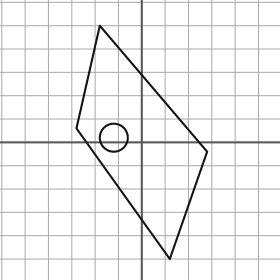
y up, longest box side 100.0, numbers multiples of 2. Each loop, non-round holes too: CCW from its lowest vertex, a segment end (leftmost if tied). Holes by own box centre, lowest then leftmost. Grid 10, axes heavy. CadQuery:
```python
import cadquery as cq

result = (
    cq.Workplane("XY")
    .moveTo(12.0, -50.0)
    .lineTo(28.0, -4.0)
    .lineTo(-18.0, 50.0)
    .lineTo(-28.0, 6.0)
    .close()
    .moveTo(-12.0, 2.0)
    .circle(6.0)
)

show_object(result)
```